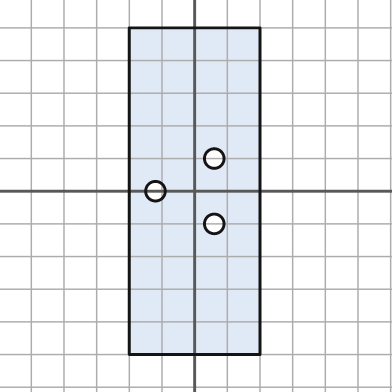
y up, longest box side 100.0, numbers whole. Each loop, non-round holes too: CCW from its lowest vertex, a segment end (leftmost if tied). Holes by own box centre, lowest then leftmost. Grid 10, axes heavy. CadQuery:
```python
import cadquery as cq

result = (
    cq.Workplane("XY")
    .moveTo(-20.0, -50.0)
    .lineTo(20.0, -50.0)
    .lineTo(20.0, 50.0)
    .lineTo(-20.0, 50.0)
    .close()
    .moveTo(6.0, -10.0)
    .circle(3.0)
    .moveTo(-12.0, 0.0)
    .circle(3.0)
    .moveTo(6.0, 10.0)
    .circle(3.0)
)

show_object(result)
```